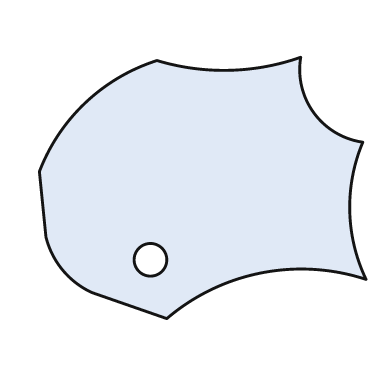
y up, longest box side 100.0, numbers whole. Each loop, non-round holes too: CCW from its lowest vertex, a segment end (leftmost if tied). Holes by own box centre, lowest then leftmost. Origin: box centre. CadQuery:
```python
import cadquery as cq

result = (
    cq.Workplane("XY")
    .moveTo(-11.0, -40.0)
    .threePointArc((18.0, -26.0), (50.0, -28.0))
    .threePointArc((45.0, -7.0), (49.0, 14.0))
    .threePointArc((34.0, 23.0), (30.0, 40.0))
    .threePointArc((8.0, 36.0), (-14.0, 39.0))
    .threePointArc((-36.0, 26.0), (-50.0, 5.0))
    .lineTo(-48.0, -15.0)
    .threePointArc((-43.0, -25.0), (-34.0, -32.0))
    .close()
    .moveTo(-16.0, -22.0)
    .circle(5.0)
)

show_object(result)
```